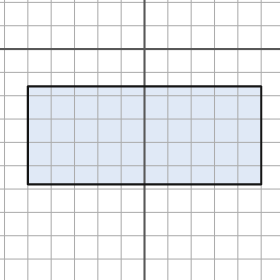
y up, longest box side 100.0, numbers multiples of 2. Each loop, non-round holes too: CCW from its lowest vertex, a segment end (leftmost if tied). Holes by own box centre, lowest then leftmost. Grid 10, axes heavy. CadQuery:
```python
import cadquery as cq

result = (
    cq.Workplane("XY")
    .moveTo(-50.0, -58.0)
    .lineTo(50.0, -58.0)
    .lineTo(50.0, -16.0)
    .lineTo(-50.0, -16.0)
    .close()
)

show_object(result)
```